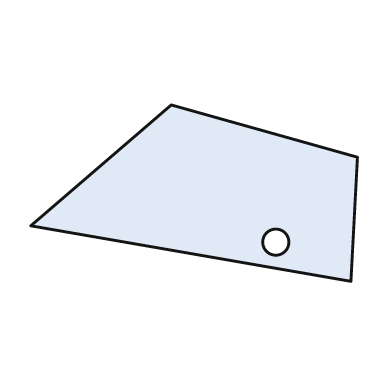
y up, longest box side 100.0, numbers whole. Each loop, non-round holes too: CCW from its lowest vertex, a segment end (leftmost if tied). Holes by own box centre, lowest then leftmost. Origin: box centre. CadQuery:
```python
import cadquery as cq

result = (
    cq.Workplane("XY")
    .moveTo(48.0, -27.0)
    .lineTo(50.0, 11.0)
    .lineTo(-7.0, 27.0)
    .lineTo(-50.0, -10.0)
    .close()
    .moveTo(25.0, -15.0)
    .circle(4.0)
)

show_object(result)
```